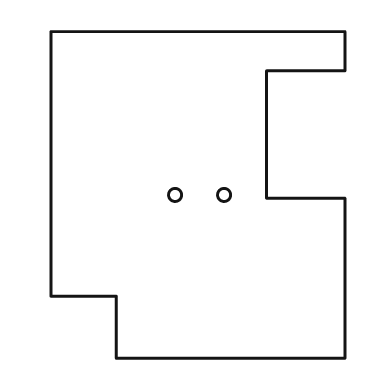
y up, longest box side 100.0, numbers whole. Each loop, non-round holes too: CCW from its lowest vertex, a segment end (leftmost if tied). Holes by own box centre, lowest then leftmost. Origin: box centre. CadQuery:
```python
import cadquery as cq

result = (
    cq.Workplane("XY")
    .moveTo(-25.0, -50.0)
    .lineTo(45.0, -50.0)
    .lineTo(45.0, -1.0)
    .lineTo(21.0, -1.0)
    .lineTo(21.0, 38.0)
    .lineTo(45.0, 38.0)
    .lineTo(45.0, 50.0)
    .lineTo(-45.0, 50.0)
    .lineTo(-45.0, -31.0)
    .lineTo(-25.0, -31.0)
    .close()
    .moveTo(-7.0, 0.0)
    .circle(2.0)
    .moveTo(8.0, 0.0)
    .circle(2.0)
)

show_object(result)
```